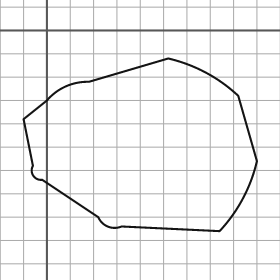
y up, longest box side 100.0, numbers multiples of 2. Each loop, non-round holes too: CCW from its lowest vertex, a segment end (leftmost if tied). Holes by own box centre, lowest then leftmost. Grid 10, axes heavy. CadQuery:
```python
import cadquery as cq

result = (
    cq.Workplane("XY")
    .moveTo(74.0, -86.0)
    .threePointArc((84.0, -72.0), (90.0, -56.0))
    .lineTo(82.0, -28.0)
    .threePointArc((68.0, -18.0), (52.0, -12.0))
    .lineTo(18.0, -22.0)
    .threePointArc((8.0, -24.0), (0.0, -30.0))
    .lineTo(-10.0, -38.0)
    .lineTo(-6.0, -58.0)
    .threePointArc((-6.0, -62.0), (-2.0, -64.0))
    .lineTo(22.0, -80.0)
    .threePointArc((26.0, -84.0), (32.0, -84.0))
    .close()
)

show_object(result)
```